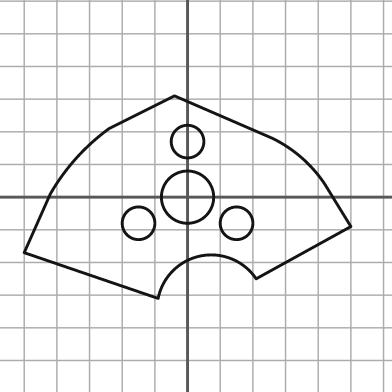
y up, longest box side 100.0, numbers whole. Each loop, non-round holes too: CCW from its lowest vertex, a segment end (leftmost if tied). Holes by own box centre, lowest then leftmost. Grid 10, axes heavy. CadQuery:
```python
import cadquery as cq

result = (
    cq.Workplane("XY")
    .moveTo(-9.0, -31.0)
    .threePointArc((4.0, -18.0), (21.0, -25.0))
    .lineTo(50.0, -9.0)
    .lineTo(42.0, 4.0)
    .threePointArc((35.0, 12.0), (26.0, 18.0))
    .lineTo(-4.0, 31.0)
    .lineTo(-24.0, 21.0)
    .threePointArc((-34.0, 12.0), (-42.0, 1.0))
    .lineTo(-50.0, -17.0)
    .close()
    .moveTo(-15.0, -8.0)
    .circle(5.0)
    .moveTo(15.0, -8.0)
    .circle(5.0)
    .moveTo(0.0, 0.0)
    .circle(8.0)
    .moveTo(0.0, 17.0)
    .circle(5.0)
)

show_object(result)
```